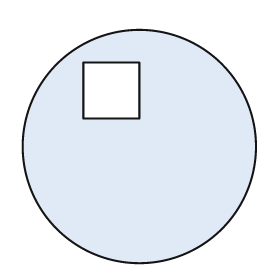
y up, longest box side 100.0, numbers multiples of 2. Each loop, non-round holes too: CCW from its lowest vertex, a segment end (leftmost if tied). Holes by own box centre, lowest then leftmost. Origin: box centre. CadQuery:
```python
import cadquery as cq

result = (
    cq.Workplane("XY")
    .moveTo(0.0, 0.0)
    .circle(50.0)
    .moveTo(-24.0, 12.0)
    .lineTo(0.0, 12.0)
    .lineTo(0.0, 36.0)
    .lineTo(-24.0, 36.0)
    .close()
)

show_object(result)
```